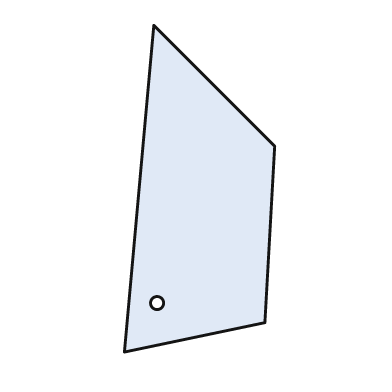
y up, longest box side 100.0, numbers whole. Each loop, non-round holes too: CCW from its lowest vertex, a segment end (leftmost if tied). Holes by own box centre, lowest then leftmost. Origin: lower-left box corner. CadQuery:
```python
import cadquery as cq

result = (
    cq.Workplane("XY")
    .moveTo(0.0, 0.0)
    .lineTo(43.0, 9.0)
    .lineTo(46.0, 63.0)
    .lineTo(9.0, 100.0)
    .close()
    .moveTo(10.0, 15.0)
    .circle(2.0)
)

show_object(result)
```